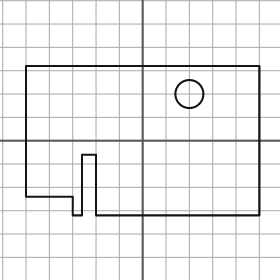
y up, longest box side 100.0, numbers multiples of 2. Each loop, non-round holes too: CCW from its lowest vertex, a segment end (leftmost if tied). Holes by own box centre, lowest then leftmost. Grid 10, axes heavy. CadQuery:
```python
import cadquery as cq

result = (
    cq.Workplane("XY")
    .moveTo(-30.0, -32.0)
    .lineTo(-26.0, -32.0)
    .lineTo(-26.0, -6.0)
    .lineTo(-20.0, -6.0)
    .lineTo(-20.0, -32.0)
    .lineTo(50.0, -32.0)
    .lineTo(50.0, 32.0)
    .lineTo(-50.0, 32.0)
    .lineTo(-50.0, -24.0)
    .lineTo(-30.0, -24.0)
    .close()
    .moveTo(20.0, 20.0)
    .circle(6.0)
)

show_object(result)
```